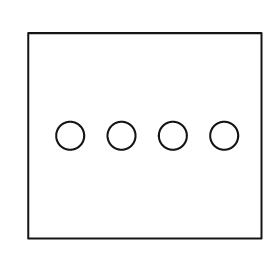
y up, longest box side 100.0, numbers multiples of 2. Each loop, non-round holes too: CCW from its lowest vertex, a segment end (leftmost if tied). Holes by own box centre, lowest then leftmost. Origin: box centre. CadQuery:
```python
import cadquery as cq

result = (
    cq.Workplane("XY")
    .moveTo(-50.0, -44.0)
    .lineTo(50.0, -44.0)
    .lineTo(50.0, 44.0)
    .lineTo(-50.0, 44.0)
    .close()
    .moveTo(-32.0, 0.0)
    .circle(6.0)
    .moveTo(-10.0, 0.0)
    .circle(6.0)
    .moveTo(12.0, 0.0)
    .circle(6.0)
    .moveTo(34.0, 0.0)
    .circle(6.0)
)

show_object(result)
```